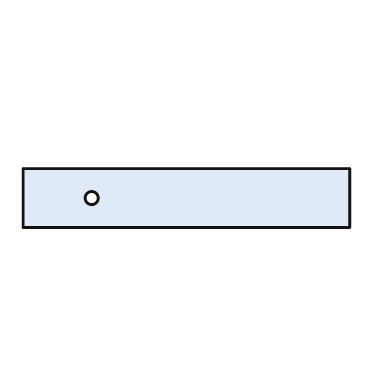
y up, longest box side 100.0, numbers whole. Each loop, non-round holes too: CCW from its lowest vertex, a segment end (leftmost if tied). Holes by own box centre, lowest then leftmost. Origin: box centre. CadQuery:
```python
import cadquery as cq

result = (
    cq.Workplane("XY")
    .moveTo(-50.0, -9.0)
    .lineTo(50.0, -9.0)
    .lineTo(50.0, 9.0)
    .lineTo(-50.0, 9.0)
    .close()
    .moveTo(-29.0, 0.0)
    .circle(2.0)
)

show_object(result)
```